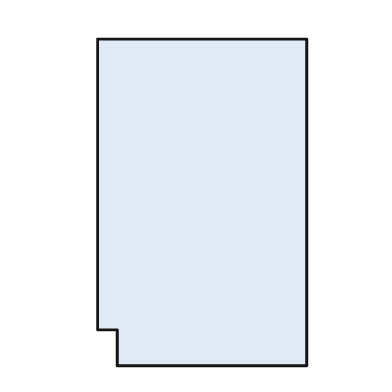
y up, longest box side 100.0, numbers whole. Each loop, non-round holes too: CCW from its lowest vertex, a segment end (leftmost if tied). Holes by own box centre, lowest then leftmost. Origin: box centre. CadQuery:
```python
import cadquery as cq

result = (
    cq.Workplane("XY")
    .moveTo(-26.0, -50.0)
    .lineTo(32.0, -50.0)
    .lineTo(32.0, 50.0)
    .lineTo(-32.0, 50.0)
    .lineTo(-32.0, -39.0)
    .lineTo(-26.0, -39.0)
    .close()
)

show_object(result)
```